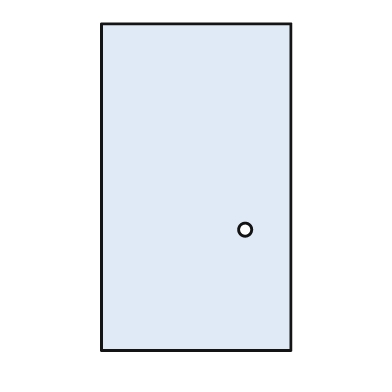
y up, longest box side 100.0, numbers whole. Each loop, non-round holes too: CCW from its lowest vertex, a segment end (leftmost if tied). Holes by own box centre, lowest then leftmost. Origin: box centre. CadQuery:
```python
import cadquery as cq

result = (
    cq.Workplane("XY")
    .moveTo(-29.0, -50.0)
    .lineTo(29.0, -50.0)
    .lineTo(29.0, 50.0)
    .lineTo(-29.0, 50.0)
    .close()
    .moveTo(15.0, -13.0)
    .circle(2.0)
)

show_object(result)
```